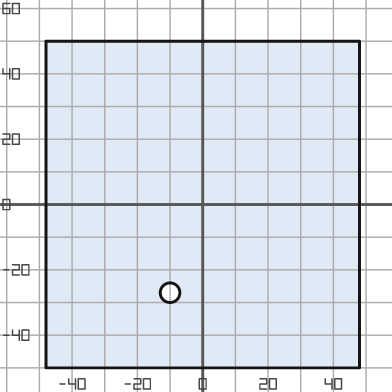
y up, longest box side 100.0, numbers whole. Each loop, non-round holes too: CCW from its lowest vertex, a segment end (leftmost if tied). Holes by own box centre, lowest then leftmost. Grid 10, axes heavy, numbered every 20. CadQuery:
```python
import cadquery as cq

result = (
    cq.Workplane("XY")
    .moveTo(-48.0, -50.0)
    .lineTo(48.0, -50.0)
    .lineTo(48.0, 50.0)
    .lineTo(-48.0, 50.0)
    .close()
    .moveTo(-10.0, -27.0)
    .circle(3.0)
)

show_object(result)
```